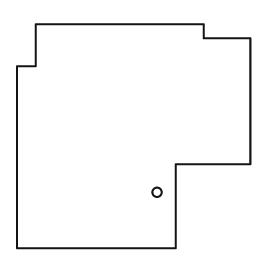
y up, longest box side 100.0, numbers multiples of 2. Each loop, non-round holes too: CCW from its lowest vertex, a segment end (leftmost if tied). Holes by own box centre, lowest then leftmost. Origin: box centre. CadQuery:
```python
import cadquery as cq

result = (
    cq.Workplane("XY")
    .moveTo(-50.0, -48.0)
    .lineTo(18.0, -48.0)
    .lineTo(18.0, -12.0)
    .lineTo(50.0, -12.0)
    .lineTo(50.0, 42.0)
    .lineTo(30.0, 42.0)
    .lineTo(30.0, 48.0)
    .lineTo(-42.0, 48.0)
    .lineTo(-42.0, 30.0)
    .lineTo(-50.0, 30.0)
    .close()
    .moveTo(10.0, -24.0)
    .circle(2.0)
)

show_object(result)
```